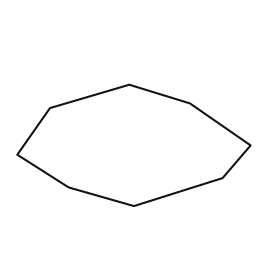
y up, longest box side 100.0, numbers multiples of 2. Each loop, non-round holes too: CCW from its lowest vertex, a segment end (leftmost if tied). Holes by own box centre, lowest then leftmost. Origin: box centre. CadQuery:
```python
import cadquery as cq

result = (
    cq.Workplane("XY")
    .moveTo(0.0, -26.0)
    .lineTo(38.0, -14.0)
    .lineTo(50.0, 0.0)
    .lineTo(24.0, 18.0)
    .lineTo(-2.0, 26.0)
    .lineTo(-36.0, 16.0)
    .lineTo(-50.0, -4.0)
    .lineTo(-28.0, -18.0)
    .close()
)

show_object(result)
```